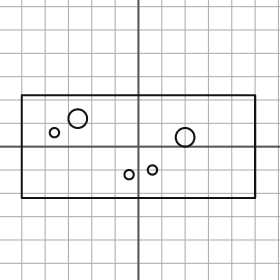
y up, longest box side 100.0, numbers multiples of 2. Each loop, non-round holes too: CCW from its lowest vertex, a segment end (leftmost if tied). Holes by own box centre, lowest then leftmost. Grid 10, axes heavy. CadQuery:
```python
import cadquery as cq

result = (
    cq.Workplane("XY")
    .moveTo(-50.0, -22.0)
    .lineTo(50.0, -22.0)
    .lineTo(50.0, 22.0)
    .lineTo(-50.0, 22.0)
    .close()
    .moveTo(-4.0, -12.0)
    .circle(2.0)
    .moveTo(6.0, -10.0)
    .circle(2.0)
    .moveTo(20.0, 4.0)
    .circle(4.0)
    .moveTo(-36.0, 6.0)
    .circle(2.0)
    .moveTo(-26.0, 12.0)
    .circle(4.0)
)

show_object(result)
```